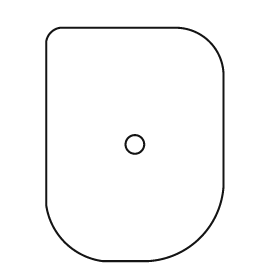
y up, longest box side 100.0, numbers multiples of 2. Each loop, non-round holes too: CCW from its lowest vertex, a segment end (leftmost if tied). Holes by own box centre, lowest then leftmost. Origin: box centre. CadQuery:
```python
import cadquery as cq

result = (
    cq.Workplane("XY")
    .moveTo(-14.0, -50.0)
    .lineTo(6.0, -50.0)
    .threePointArc((28.0, -40.0), (38.0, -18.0))
    .lineTo(38.0, 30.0)
    .threePointArc((32.0, 44.0), (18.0, 50.0))
    .lineTo(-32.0, 50.0)
    .threePointArc((-36.0, 48.0), (-38.0, 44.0))
    .lineTo(-38.0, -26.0)
    .threePointArc((-30.0, -42.0), (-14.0, -50.0))
    .close()
    .moveTo(0.0, 0.0)
    .circle(4.0)
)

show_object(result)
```